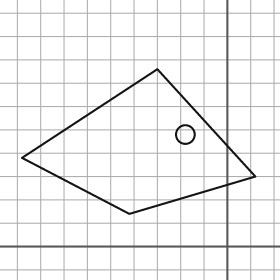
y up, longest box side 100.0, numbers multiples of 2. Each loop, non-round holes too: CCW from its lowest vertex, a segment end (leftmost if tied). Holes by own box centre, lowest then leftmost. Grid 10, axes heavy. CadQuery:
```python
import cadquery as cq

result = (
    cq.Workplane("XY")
    .moveTo(-42.0, 14.0)
    .lineTo(12.0, 30.0)
    .lineTo(-30.0, 76.0)
    .lineTo(-88.0, 38.0)
    .close()
    .moveTo(-18.0, 48.0)
    .circle(4.0)
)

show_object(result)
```